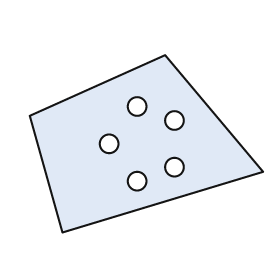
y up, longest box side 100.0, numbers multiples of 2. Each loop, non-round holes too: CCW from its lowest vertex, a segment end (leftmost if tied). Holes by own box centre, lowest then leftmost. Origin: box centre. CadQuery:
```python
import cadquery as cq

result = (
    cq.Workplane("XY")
    .moveTo(-36.0, -38.0)
    .lineTo(50.0, -12.0)
    .lineTo(8.0, 38.0)
    .lineTo(-50.0, 12.0)
    .close()
    .moveTo(-4.0, -16.0)
    .circle(4.0)
    .moveTo(12.0, -10.0)
    .circle(4.0)
    .moveTo(-16.0, 0.0)
    .circle(4.0)
    .moveTo(12.0, 10.0)
    .circle(4.0)
    .moveTo(-4.0, 16.0)
    .circle(4.0)
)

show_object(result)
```